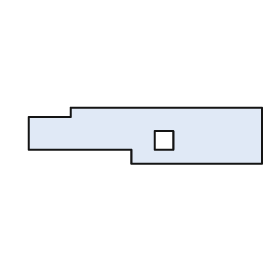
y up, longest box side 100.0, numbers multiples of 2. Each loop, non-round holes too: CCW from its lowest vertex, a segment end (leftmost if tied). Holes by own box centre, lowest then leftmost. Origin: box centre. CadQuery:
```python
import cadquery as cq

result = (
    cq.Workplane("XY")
    .moveTo(-6.0, -12.0)
    .lineTo(50.0, -12.0)
    .lineTo(50.0, 12.0)
    .lineTo(-32.0, 12.0)
    .lineTo(-32.0, 8.0)
    .lineTo(-50.0, 8.0)
    .lineTo(-50.0, -6.0)
    .lineTo(-6.0, -6.0)
    .close()
    .moveTo(4.0, -6.0)
    .lineTo(12.0, -6.0)
    .lineTo(12.0, 2.0)
    .lineTo(4.0, 2.0)
    .close()
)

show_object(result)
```